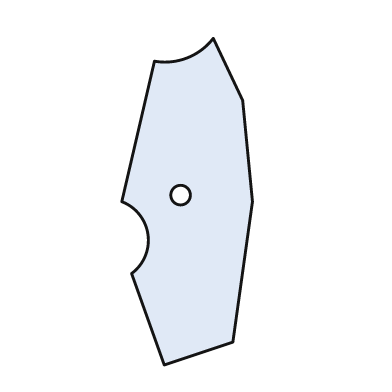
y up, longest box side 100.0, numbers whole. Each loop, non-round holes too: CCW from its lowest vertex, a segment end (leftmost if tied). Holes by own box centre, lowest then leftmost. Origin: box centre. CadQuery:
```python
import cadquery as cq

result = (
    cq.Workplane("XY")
    .moveTo(-7.0, -50.0)
    .lineTo(14.0, -43.0)
    .lineTo(20.0, 0.0)
    .lineTo(17.0, 31.0)
    .lineTo(8.0, 50.0)
    .threePointArc((0.0, 44.0), (-10.0, 43.0))
    .lineTo(-20.0, 0.0)
    .threePointArc((-12.0, -10.0), (-17.0, -22.0))
    .close()
    .moveTo(-2.0, 2.0)
    .circle(3.0)
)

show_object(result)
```